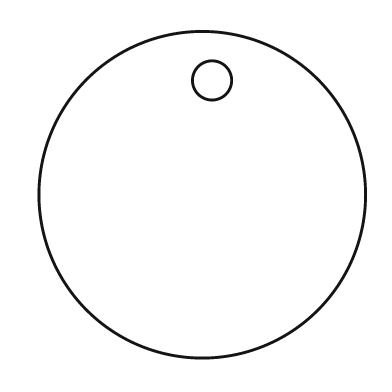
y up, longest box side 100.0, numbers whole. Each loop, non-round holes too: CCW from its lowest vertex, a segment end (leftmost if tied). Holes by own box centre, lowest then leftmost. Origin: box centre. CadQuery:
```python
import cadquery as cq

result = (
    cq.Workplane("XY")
    .moveTo(0.0, 0.0)
    .circle(50.0)
    .moveTo(3.0, 35.0)
    .circle(6.0)
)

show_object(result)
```